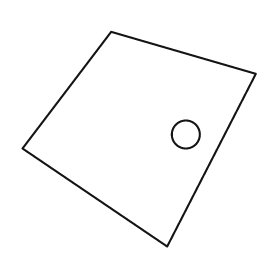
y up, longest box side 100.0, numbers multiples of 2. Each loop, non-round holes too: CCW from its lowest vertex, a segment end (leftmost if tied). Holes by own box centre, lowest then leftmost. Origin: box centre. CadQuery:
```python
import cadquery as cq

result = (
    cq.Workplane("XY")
    .moveTo(12.0, -46.0)
    .lineTo(50.0, 28.0)
    .lineTo(-12.0, 46.0)
    .lineTo(-50.0, -4.0)
    .close()
    .moveTo(20.0, 2.0)
    .circle(6.0)
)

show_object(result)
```